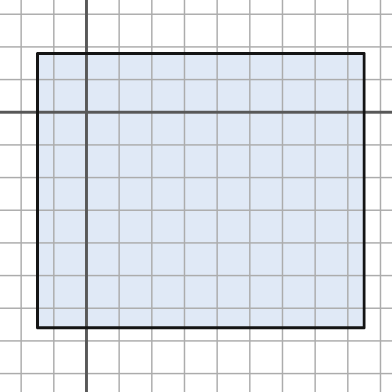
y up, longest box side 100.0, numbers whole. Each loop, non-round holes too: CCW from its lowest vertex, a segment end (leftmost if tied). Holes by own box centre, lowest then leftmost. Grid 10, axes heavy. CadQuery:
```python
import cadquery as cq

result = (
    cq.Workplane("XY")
    .moveTo(-15.0, -66.0)
    .lineTo(85.0, -66.0)
    .lineTo(85.0, 18.0)
    .lineTo(-15.0, 18.0)
    .close()
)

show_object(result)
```